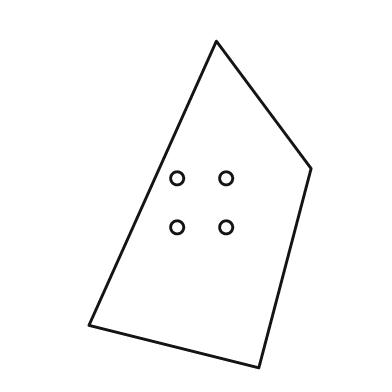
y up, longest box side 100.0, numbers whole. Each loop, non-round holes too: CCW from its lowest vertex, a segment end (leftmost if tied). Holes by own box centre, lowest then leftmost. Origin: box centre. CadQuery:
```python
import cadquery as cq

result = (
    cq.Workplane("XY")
    .moveTo(18.0, -50.0)
    .lineTo(34.0, 11.0)
    .lineTo(5.0, 50.0)
    .lineTo(-34.0, -37.0)
    .close()
    .moveTo(-7.0, -7.0)
    .circle(2.0)
    .moveTo(8.0, -7.0)
    .circle(2.0)
    .moveTo(-7.0, 8.0)
    .circle(2.0)
    .moveTo(8.0, 8.0)
    .circle(2.0)
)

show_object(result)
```